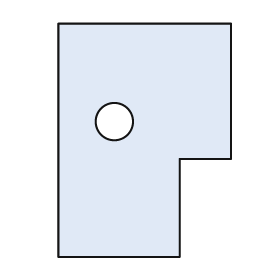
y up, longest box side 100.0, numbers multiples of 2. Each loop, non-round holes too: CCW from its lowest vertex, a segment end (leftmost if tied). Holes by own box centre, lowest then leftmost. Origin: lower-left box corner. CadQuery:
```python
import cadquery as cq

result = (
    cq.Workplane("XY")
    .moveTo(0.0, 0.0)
    .lineTo(52.0, 0.0)
    .lineTo(52.0, 42.0)
    .lineTo(74.0, 42.0)
    .lineTo(74.0, 100.0)
    .lineTo(0.0, 100.0)
    .close()
    .moveTo(24.0, 58.0)
    .circle(8.0)
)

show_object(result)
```